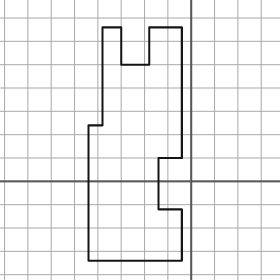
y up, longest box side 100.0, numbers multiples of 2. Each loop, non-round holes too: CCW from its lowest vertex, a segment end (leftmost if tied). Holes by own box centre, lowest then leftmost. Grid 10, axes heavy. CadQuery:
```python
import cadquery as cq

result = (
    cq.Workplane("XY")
    .moveTo(-44.0, -34.0)
    .lineTo(-4.0, -34.0)
    .lineTo(-4.0, -12.0)
    .lineTo(-14.0, -12.0)
    .lineTo(-14.0, 10.0)
    .lineTo(-4.0, 10.0)
    .lineTo(-4.0, 66.0)
    .lineTo(-18.0, 66.0)
    .lineTo(-18.0, 50.0)
    .lineTo(-30.0, 50.0)
    .lineTo(-30.0, 66.0)
    .lineTo(-38.0, 66.0)
    .lineTo(-38.0, 24.0)
    .lineTo(-44.0, 24.0)
    .close()
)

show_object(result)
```